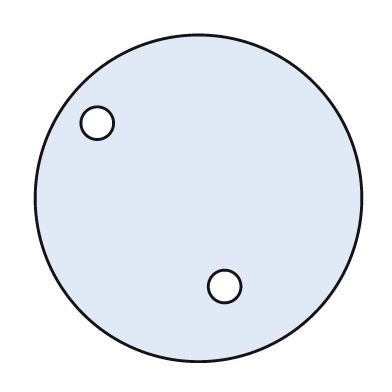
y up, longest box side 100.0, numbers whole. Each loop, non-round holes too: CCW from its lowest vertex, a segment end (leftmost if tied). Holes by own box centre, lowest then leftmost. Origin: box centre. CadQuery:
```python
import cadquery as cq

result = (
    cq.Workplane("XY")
    .moveTo(0.0, 0.0)
    .circle(50.0)
    .moveTo(8.0, -27.0)
    .circle(5.0)
    .moveTo(-31.0, 23.0)
    .circle(5.0)
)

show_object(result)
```